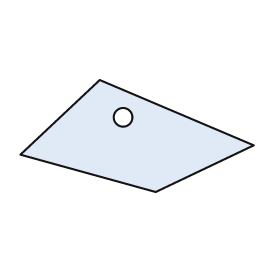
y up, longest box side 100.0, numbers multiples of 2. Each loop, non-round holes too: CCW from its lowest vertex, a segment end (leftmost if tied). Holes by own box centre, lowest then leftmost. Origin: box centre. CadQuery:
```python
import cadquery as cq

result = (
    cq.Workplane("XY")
    .moveTo(8.0, -24.0)
    .lineTo(50.0, -4.0)
    .lineTo(-16.0, 24.0)
    .lineTo(-50.0, -8.0)
    .close()
    .moveTo(-6.0, 8.0)
    .circle(4.0)
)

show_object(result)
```